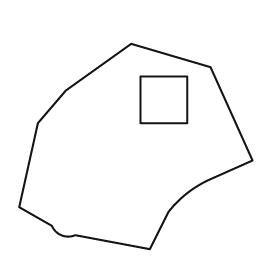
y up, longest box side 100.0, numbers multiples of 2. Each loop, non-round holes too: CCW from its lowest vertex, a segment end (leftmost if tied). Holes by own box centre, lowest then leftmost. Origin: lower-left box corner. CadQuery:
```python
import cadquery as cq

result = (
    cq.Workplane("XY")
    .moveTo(56.0, 0.0)
    .lineTo(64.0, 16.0)
    .threePointArc((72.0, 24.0), (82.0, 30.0))
    .lineTo(100.0, 38.0)
    .lineTo(82.0, 78.0)
    .lineTo(48.0, 88.0)
    .lineTo(20.0, 68.0)
    .lineTo(8.0, 54.0)
    .lineTo(0.0, 18.0)
    .lineTo(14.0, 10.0)
    .threePointArc((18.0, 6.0), (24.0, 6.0))
    .close()
    .moveTo(52.0, 54.0)
    .lineTo(72.0, 54.0)
    .lineTo(72.0, 74.0)
    .lineTo(52.0, 74.0)
    .close()
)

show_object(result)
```